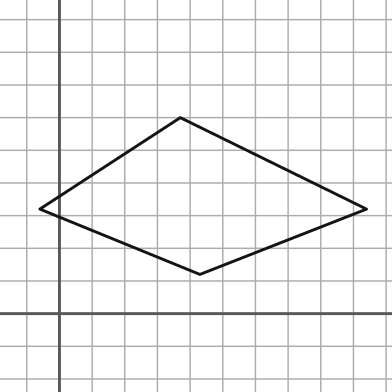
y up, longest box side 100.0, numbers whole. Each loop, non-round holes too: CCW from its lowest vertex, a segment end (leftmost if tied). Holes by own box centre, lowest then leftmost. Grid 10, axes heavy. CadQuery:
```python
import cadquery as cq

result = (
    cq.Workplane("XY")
    .moveTo(43.0, 12.0)
    .lineTo(94.0, 32.0)
    .lineTo(37.0, 60.0)
    .lineTo(-6.0, 32.0)
    .close()
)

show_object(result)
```